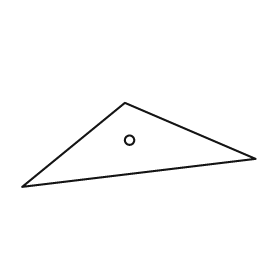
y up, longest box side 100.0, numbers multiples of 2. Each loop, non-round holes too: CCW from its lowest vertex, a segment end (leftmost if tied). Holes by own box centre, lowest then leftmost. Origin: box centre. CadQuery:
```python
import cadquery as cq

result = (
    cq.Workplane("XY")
    .moveTo(-50.0, -18.0)
    .lineTo(50.0, -6.0)
    .lineTo(-6.0, 18.0)
    .close()
    .moveTo(-4.0, 2.0)
    .circle(2.0)
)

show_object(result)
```